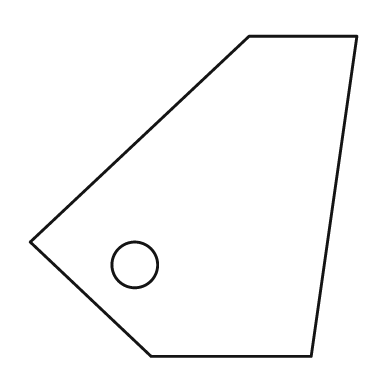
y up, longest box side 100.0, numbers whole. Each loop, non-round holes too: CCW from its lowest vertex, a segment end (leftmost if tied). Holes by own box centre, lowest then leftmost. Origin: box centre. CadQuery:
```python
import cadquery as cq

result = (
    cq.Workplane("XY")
    .moveTo(-13.0, -49.0)
    .lineTo(36.0, -49.0)
    .lineTo(50.0, 49.0)
    .lineTo(17.0, 49.0)
    .lineTo(-50.0, -14.0)
    .close()
    .moveTo(-18.0, -21.0)
    .circle(7.0)
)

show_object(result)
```